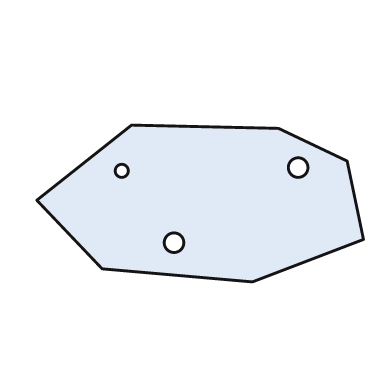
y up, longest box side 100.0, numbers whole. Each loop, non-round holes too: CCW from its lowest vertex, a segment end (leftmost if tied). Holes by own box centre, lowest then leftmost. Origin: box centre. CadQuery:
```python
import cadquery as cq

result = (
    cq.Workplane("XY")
    .moveTo(16.0, -24.0)
    .lineTo(50.0, -11.0)
    .lineTo(45.0, 13.0)
    .lineTo(24.0, 23.0)
    .lineTo(-21.0, 24.0)
    .lineTo(-50.0, 1.0)
    .lineTo(-30.0, -20.0)
    .close()
    .moveTo(-8.0, -12.0)
    .circle(3.0)
    .moveTo(-24.0, 10.0)
    .circle(2.0)
    .moveTo(30.0, 11.0)
    .circle(3.0)
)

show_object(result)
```